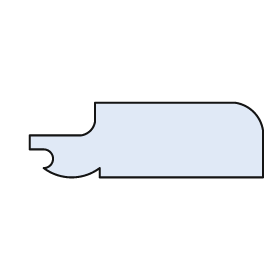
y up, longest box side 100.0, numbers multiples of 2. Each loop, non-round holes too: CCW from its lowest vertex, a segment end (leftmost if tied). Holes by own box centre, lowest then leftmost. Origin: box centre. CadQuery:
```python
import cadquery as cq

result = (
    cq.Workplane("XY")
    .moveTo(-20.0, -16.0)
    .lineTo(50.0, -16.0)
    .lineTo(50.0, 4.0)
    .threePointArc((46.0, 12.0), (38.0, 16.0))
    .lineTo(-22.0, 16.0)
    .lineTo(-22.0, 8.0)
    .threePointArc((-24.0, 4.0), (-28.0, 2.0))
    .lineTo(-50.0, 2.0)
    .lineTo(-50.0, -4.0)
    .lineTo(-44.0, -4.0)
    .threePointArc((-40.0, -8.0), (-44.0, -12.0))
    .threePointArc((-32.0, -16.0), (-20.0, -12.0))
    .close()
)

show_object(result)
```